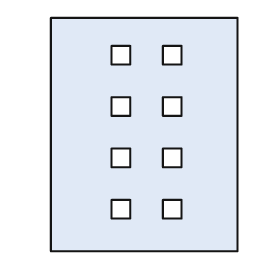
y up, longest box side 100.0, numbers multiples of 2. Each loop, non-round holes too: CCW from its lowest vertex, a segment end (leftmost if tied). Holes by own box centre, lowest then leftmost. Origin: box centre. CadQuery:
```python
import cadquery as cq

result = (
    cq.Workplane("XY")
    .moveTo(-40.0, -50.0)
    .lineTo(40.0, -50.0)
    .lineTo(40.0, 50.0)
    .lineTo(-40.0, 50.0)
    .close()
    .moveTo(-14.0, -36.0)
    .lineTo(-6.0, -36.0)
    .lineTo(-6.0, -28.0)
    .lineTo(-14.0, -28.0)
    .close()
    .moveTo(8.0, -36.0)
    .lineTo(16.0, -36.0)
    .lineTo(16.0, -28.0)
    .lineTo(8.0, -28.0)
    .close()
    .moveTo(-14.0, -14.0)
    .lineTo(-6.0, -14.0)
    .lineTo(-6.0, -6.0)
    .lineTo(-14.0, -6.0)
    .close()
    .moveTo(8.0, -14.0)
    .lineTo(16.0, -14.0)
    .lineTo(16.0, -6.0)
    .lineTo(8.0, -6.0)
    .close()
    .moveTo(-14.0, 8.0)
    .lineTo(-6.0, 8.0)
    .lineTo(-6.0, 16.0)
    .lineTo(-14.0, 16.0)
    .close()
    .moveTo(8.0, 8.0)
    .lineTo(16.0, 8.0)
    .lineTo(16.0, 16.0)
    .lineTo(8.0, 16.0)
    .close()
    .moveTo(-14.0, 30.0)
    .lineTo(-6.0, 30.0)
    .lineTo(-6.0, 38.0)
    .lineTo(-14.0, 38.0)
    .close()
    .moveTo(8.0, 30.0)
    .lineTo(16.0, 30.0)
    .lineTo(16.0, 38.0)
    .lineTo(8.0, 38.0)
    .close()
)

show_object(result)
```